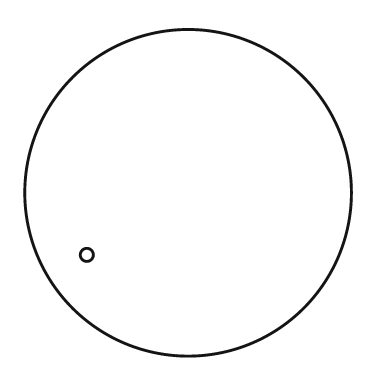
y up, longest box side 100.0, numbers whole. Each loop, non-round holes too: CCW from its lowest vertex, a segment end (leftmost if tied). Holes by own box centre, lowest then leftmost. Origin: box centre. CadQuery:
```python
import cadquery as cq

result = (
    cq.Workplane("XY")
    .moveTo(0.0, 0.0)
    .circle(50.0)
    .moveTo(-31.0, -19.0)
    .circle(2.0)
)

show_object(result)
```